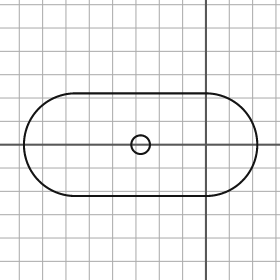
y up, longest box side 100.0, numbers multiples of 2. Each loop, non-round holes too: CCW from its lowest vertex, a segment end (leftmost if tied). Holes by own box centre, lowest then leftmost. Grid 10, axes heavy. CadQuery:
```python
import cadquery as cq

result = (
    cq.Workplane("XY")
    .moveTo(-56.0, -22.0)
    .lineTo(0.0, -22.0)
    .threePointArc((22.0, 0.0), (0.0, 22.0))
    .lineTo(-56.0, 22.0)
    .threePointArc((-78.0, 0.0), (-56.0, -22.0))
    .close()
    .moveTo(-28.0, 0.0)
    .circle(4.0)
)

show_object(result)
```